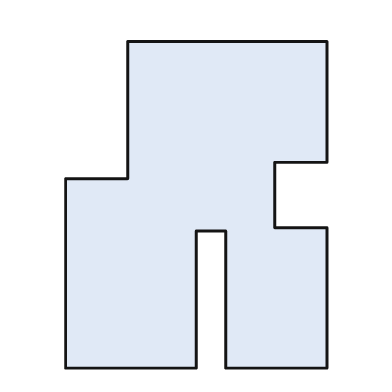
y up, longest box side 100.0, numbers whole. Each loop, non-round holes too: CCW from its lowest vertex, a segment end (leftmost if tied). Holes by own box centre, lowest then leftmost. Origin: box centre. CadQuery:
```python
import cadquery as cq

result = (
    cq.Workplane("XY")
    .moveTo(-40.0, -50.0)
    .lineTo(0.0, -50.0)
    .lineTo(0.0, -8.0)
    .lineTo(9.0, -8.0)
    .lineTo(9.0, -50.0)
    .lineTo(40.0, -50.0)
    .lineTo(40.0, -7.0)
    .lineTo(24.0, -7.0)
    .lineTo(24.0, 13.0)
    .lineTo(40.0, 13.0)
    .lineTo(40.0, 50.0)
    .lineTo(-21.0, 50.0)
    .lineTo(-21.0, 8.0)
    .lineTo(-40.0, 8.0)
    .close()
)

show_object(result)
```